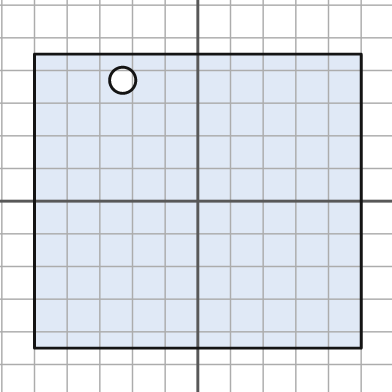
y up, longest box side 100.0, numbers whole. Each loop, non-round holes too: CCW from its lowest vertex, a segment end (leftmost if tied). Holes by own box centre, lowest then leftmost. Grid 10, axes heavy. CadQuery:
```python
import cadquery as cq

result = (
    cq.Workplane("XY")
    .moveTo(-50.0, -45.0)
    .lineTo(50.0, -45.0)
    .lineTo(50.0, 45.0)
    .lineTo(-50.0, 45.0)
    .close()
    .moveTo(-23.0, 37.0)
    .circle(4.0)
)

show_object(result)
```